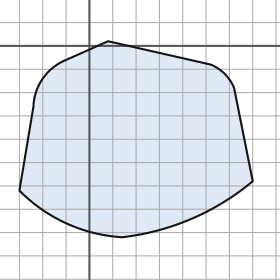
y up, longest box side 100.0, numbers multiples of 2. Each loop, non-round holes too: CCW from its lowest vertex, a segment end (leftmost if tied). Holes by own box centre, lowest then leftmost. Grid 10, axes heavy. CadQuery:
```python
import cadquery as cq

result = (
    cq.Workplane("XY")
    .moveTo(14.0, -82.0)
    .threePointArc((44.0, -74.0), (70.0, -58.0))
    .lineTo(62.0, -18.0)
    .threePointArc((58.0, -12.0), (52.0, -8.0))
    .lineTo(8.0, 2.0)
    .lineTo(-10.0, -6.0)
    .threePointArc((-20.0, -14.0), (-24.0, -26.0))
    .lineTo(-30.0, -62.0)
    .threePointArc((-10.0, -76.0), (14.0, -82.0))
    .close()
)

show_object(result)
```